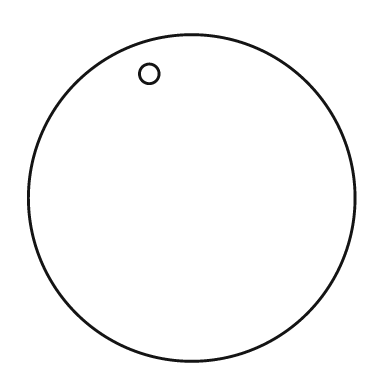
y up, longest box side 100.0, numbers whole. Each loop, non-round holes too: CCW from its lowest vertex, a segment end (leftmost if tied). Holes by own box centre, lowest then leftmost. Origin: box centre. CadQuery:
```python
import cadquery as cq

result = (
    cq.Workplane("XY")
    .moveTo(0.0, 0.0)
    .circle(50.0)
    .moveTo(-13.0, 38.0)
    .circle(3.0)
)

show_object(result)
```